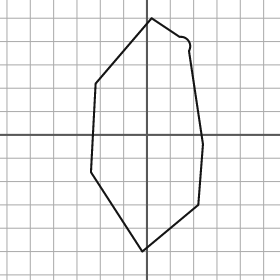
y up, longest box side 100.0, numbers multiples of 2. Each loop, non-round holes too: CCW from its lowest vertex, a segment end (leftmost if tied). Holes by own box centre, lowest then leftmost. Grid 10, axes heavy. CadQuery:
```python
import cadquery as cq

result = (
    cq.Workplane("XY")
    .moveTo(-2.0, -50.0)
    .lineTo(22.0, -30.0)
    .lineTo(24.0, -4.0)
    .lineTo(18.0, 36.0)
    .threePointArc((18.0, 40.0), (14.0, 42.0))
    .lineTo(2.0, 50.0)
    .lineTo(-22.0, 22.0)
    .lineTo(-24.0, -16.0)
    .close()
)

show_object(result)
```